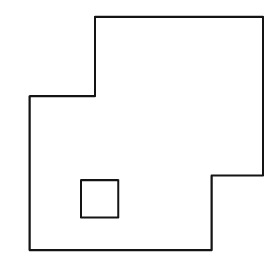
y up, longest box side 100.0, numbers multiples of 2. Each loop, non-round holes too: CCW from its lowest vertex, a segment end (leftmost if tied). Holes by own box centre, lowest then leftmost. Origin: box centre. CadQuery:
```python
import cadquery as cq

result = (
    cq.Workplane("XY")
    .moveTo(-50.0, -50.0)
    .lineTo(28.0, -50.0)
    .lineTo(28.0, -18.0)
    .lineTo(50.0, -18.0)
    .lineTo(50.0, 50.0)
    .lineTo(-22.0, 50.0)
    .lineTo(-22.0, 16.0)
    .lineTo(-50.0, 16.0)
    .close()
    .moveTo(-28.0, -36.0)
    .lineTo(-12.0, -36.0)
    .lineTo(-12.0, -20.0)
    .lineTo(-28.0, -20.0)
    .close()
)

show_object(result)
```